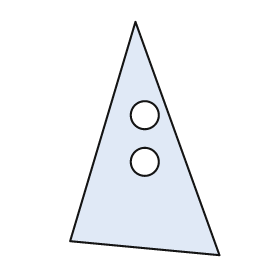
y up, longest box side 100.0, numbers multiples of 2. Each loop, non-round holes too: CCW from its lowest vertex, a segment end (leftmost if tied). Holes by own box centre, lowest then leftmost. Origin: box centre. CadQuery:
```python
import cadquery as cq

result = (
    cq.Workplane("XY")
    .moveTo(32.0, -50.0)
    .lineTo(-4.0, 50.0)
    .lineTo(-32.0, -44.0)
    .close()
    .moveTo(0.0, -10.0)
    .circle(6.0)
    .moveTo(0.0, 10.0)
    .circle(6.0)
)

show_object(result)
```